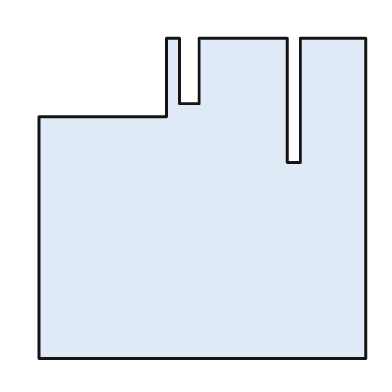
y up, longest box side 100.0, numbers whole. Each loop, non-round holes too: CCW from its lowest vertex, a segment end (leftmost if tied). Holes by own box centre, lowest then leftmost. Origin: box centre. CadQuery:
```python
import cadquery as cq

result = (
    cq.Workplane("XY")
    .moveTo(-50.0, -49.0)
    .lineTo(50.0, -49.0)
    .lineTo(50.0, 49.0)
    .lineTo(30.0, 49.0)
    .lineTo(30.0, 11.0)
    .lineTo(26.0, 11.0)
    .lineTo(26.0, 49.0)
    .lineTo(-1.0, 49.0)
    .lineTo(-1.0, 29.0)
    .lineTo(-7.0, 29.0)
    .lineTo(-7.0, 49.0)
    .lineTo(-11.0, 49.0)
    .lineTo(-11.0, 25.0)
    .lineTo(-50.0, 25.0)
    .close()
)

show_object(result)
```